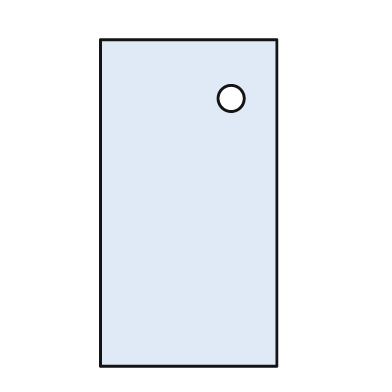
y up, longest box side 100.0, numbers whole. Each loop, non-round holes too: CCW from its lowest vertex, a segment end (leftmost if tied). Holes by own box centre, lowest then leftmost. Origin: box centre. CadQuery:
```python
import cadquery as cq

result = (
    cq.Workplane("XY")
    .moveTo(-27.0, -50.0)
    .lineTo(27.0, -50.0)
    .lineTo(27.0, 50.0)
    .lineTo(-27.0, 50.0)
    .close()
    .moveTo(13.0, 32.0)
    .circle(4.0)
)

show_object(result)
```